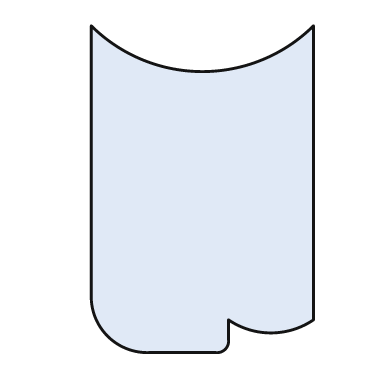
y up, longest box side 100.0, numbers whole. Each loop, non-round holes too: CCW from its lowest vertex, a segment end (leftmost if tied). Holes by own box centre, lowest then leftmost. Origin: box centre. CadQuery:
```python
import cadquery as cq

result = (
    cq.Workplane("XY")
    .moveTo(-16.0, -50.0)
    .lineTo(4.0, -50.0)
    .threePointArc((7.0, -49.0), (8.0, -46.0))
    .lineTo(8.0, -40.0)
    .threePointArc((21.0, -44.0), (34.0, -40.0))
    .lineTo(34.0, 50.0)
    .threePointArc((0.0, 36.0), (-34.0, 50.0))
    .lineTo(-34.0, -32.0)
    .threePointArc((-29.0, -45.0), (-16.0, -50.0))
    .close()
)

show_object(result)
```